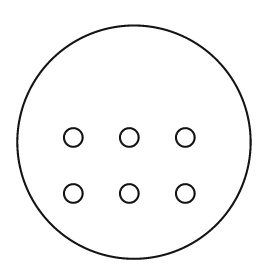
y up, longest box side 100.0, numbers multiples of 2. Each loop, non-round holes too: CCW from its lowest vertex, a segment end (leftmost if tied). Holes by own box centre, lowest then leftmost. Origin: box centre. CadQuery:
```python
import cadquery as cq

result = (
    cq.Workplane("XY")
    .moveTo(0.0, 0.0)
    .circle(50.0)
    .moveTo(-26.0, -22.0)
    .circle(4.0)
    .moveTo(-2.0, -22.0)
    .circle(4.0)
    .moveTo(22.0, -22.0)
    .circle(4.0)
    .moveTo(-26.0, 2.0)
    .circle(4.0)
    .moveTo(-2.0, 2.0)
    .circle(4.0)
    .moveTo(22.0, 2.0)
    .circle(4.0)
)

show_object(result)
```